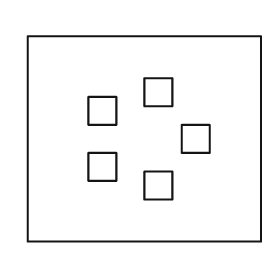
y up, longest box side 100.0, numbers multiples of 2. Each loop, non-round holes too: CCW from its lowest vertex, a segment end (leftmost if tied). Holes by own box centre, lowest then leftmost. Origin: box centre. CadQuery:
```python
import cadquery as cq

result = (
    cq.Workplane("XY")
    .moveTo(-50.0, -44.0)
    .lineTo(50.0, -44.0)
    .lineTo(50.0, 44.0)
    .lineTo(-50.0, 44.0)
    .close()
    .moveTo(0.0, -26.0)
    .lineTo(12.0, -26.0)
    .lineTo(12.0, -14.0)
    .lineTo(0.0, -14.0)
    .close()
    .moveTo(-24.0, -18.0)
    .lineTo(-12.0, -18.0)
    .lineTo(-12.0, -6.0)
    .lineTo(-24.0, -6.0)
    .close()
    .moveTo(16.0, -6.0)
    .lineTo(28.0, -6.0)
    .lineTo(28.0, 6.0)
    .lineTo(16.0, 6.0)
    .close()
    .moveTo(-24.0, 6.0)
    .lineTo(-12.0, 6.0)
    .lineTo(-12.0, 18.0)
    .lineTo(-24.0, 18.0)
    .close()
    .moveTo(0.0, 14.0)
    .lineTo(12.0, 14.0)
    .lineTo(12.0, 26.0)
    .lineTo(0.0, 26.0)
    .close()
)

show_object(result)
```